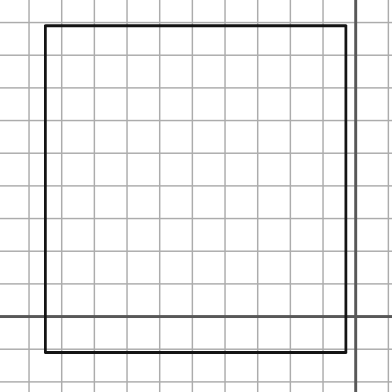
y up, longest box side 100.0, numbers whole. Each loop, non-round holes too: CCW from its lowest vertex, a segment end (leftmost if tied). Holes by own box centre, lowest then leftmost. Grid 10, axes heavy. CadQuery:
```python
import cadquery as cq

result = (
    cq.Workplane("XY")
    .moveTo(-95.0, -11.0)
    .lineTo(-3.0, -11.0)
    .lineTo(-3.0, 89.0)
    .lineTo(-95.0, 89.0)
    .close()
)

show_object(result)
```